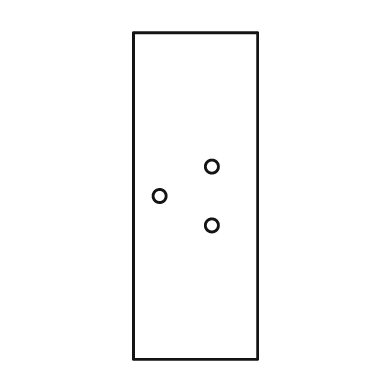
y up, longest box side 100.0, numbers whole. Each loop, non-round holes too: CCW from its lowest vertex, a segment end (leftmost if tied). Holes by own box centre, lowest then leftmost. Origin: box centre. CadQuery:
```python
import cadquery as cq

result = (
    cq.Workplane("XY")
    .moveTo(-19.0, -50.0)
    .lineTo(19.0, -50.0)
    .lineTo(19.0, 50.0)
    .lineTo(-19.0, 50.0)
    .close()
    .moveTo(5.0, -9.0)
    .circle(2.0)
    .moveTo(-11.0, 0.0)
    .circle(2.0)
    .moveTo(5.0, 9.0)
    .circle(2.0)
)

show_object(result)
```